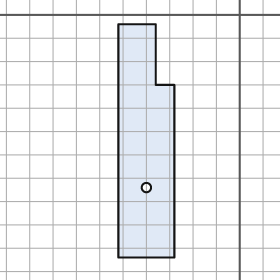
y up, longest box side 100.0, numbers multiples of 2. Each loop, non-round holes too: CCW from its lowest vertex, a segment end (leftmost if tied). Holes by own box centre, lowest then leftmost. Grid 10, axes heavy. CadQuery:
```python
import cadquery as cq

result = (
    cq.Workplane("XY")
    .moveTo(-52.0, -104.0)
    .lineTo(-28.0, -104.0)
    .lineTo(-28.0, -30.0)
    .lineTo(-36.0, -30.0)
    .lineTo(-36.0, -4.0)
    .lineTo(-52.0, -4.0)
    .close()
    .moveTo(-40.0, -74.0)
    .circle(2.0)
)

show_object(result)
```